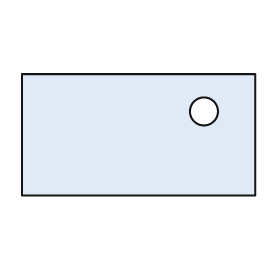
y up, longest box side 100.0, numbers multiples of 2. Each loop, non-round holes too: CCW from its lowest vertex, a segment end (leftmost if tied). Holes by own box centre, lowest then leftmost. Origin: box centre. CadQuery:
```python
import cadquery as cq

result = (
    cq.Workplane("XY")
    .moveTo(-50.0, -26.0)
    .lineTo(50.0, -26.0)
    .lineTo(50.0, 26.0)
    .lineTo(-50.0, 26.0)
    .close()
    .moveTo(28.0, 10.0)
    .circle(6.0)
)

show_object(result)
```